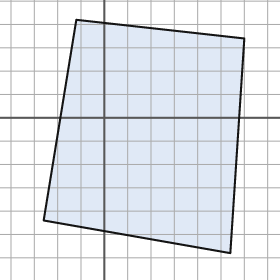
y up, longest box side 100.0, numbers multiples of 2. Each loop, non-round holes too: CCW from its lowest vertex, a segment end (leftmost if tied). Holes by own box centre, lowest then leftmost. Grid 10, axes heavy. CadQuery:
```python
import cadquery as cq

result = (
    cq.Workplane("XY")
    .moveTo(54.0, -58.0)
    .lineTo(60.0, 34.0)
    .lineTo(-12.0, 42.0)
    .lineTo(-26.0, -44.0)
    .close()
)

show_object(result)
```